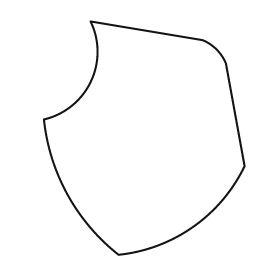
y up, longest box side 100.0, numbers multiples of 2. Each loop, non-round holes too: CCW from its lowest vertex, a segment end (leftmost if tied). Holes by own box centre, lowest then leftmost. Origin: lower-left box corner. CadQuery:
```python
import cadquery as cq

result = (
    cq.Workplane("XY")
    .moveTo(32.0, 0.0)
    .threePointArc((64.0, 12.0), (86.0, 38.0))
    .lineTo(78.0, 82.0)
    .threePointArc((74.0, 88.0), (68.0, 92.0))
    .lineTo(20.0, 100.0)
    .threePointArc((20.0, 74.0), (0.0, 58.0))
    .threePointArc((10.0, 26.0), (32.0, 0.0))
    .close()
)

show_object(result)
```